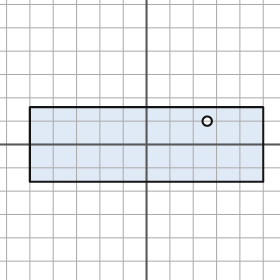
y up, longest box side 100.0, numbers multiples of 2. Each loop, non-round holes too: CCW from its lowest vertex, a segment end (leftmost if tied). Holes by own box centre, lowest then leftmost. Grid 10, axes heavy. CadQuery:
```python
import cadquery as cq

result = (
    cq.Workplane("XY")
    .moveTo(-50.0, -16.0)
    .lineTo(50.0, -16.0)
    .lineTo(50.0, 16.0)
    .lineTo(-50.0, 16.0)
    .close()
    .moveTo(26.0, 10.0)
    .circle(2.0)
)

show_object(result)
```